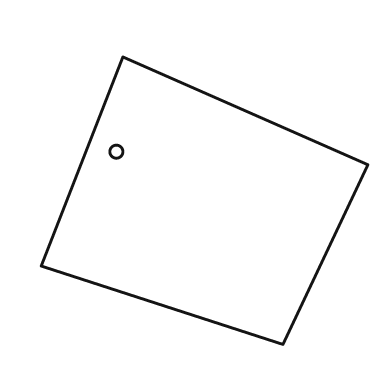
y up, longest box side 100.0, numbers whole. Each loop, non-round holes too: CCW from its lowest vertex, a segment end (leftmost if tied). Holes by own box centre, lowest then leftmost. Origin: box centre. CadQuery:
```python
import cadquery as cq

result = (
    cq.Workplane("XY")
    .moveTo(24.0, -44.0)
    .lineTo(50.0, 11.0)
    .lineTo(-25.0, 44.0)
    .lineTo(-50.0, -20.0)
    .close()
    .moveTo(-27.0, 15.0)
    .circle(2.0)
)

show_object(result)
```